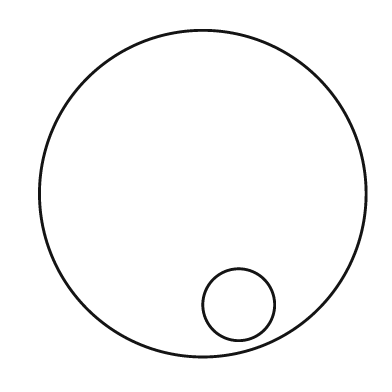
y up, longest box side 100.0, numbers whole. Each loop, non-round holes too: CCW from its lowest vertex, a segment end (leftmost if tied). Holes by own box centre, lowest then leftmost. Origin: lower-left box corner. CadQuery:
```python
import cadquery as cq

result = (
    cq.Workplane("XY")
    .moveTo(50.0, 50.0)
    .circle(50.0)
    .moveTo(61.0, 16.0)
    .circle(11.0)
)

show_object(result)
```